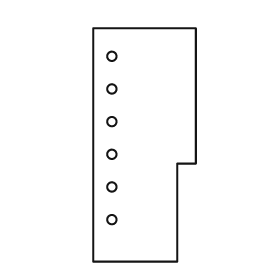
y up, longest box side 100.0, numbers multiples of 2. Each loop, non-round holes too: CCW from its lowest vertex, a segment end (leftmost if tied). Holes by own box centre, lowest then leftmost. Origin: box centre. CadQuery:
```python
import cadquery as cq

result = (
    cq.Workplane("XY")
    .moveTo(-22.0, -50.0)
    .lineTo(14.0, -50.0)
    .lineTo(14.0, -8.0)
    .lineTo(22.0, -8.0)
    .lineTo(22.0, 50.0)
    .lineTo(-22.0, 50.0)
    .close()
    .moveTo(-14.0, -32.0)
    .circle(2.0)
    .moveTo(-14.0, -18.0)
    .circle(2.0)
    .moveTo(-14.0, -4.0)
    .circle(2.0)
    .moveTo(-14.0, 10.0)
    .circle(2.0)
    .moveTo(-14.0, 24.0)
    .circle(2.0)
    .moveTo(-14.0, 38.0)
    .circle(2.0)
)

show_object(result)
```